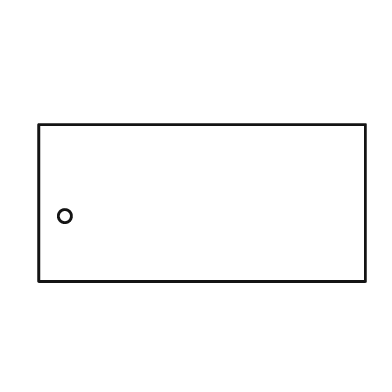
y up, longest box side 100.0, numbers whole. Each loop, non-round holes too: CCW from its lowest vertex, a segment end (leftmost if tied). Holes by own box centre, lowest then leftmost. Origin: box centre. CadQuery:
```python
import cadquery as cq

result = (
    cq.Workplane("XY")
    .moveTo(-50.0, -24.0)
    .lineTo(50.0, -24.0)
    .lineTo(50.0, 24.0)
    .lineTo(-50.0, 24.0)
    .close()
    .moveTo(-42.0, -4.0)
    .circle(2.0)
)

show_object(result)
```